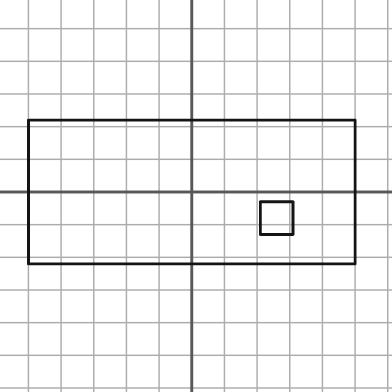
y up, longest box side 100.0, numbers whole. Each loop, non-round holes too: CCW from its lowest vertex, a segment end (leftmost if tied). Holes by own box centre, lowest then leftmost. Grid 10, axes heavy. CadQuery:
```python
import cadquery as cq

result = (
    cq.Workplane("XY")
    .moveTo(-50.0, -22.0)
    .lineTo(50.0, -22.0)
    .lineTo(50.0, 22.0)
    .lineTo(-50.0, 22.0)
    .close()
    .moveTo(21.0, -13.0)
    .lineTo(31.0, -13.0)
    .lineTo(31.0, -3.0)
    .lineTo(21.0, -3.0)
    .close()
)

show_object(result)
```